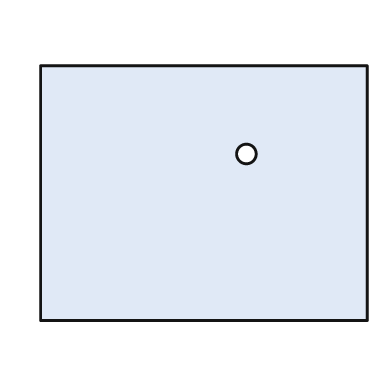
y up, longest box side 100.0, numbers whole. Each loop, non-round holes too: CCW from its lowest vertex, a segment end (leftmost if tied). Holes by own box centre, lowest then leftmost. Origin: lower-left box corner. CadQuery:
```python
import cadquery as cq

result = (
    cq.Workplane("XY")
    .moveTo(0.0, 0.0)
    .lineTo(100.0, 0.0)
    .lineTo(100.0, 78.0)
    .lineTo(0.0, 78.0)
    .close()
    .moveTo(63.0, 51.0)
    .circle(3.0)
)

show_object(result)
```